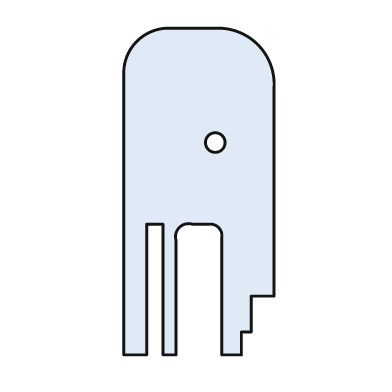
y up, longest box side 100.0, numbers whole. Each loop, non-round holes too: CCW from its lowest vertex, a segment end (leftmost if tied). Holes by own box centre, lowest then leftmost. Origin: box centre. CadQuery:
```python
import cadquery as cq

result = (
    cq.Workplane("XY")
    .moveTo(-23.0, -50.0)
    .lineTo(-16.0, -50.0)
    .lineTo(-16.0, -10.0)
    .lineTo(-11.0, -10.0)
    .lineTo(-11.0, -50.0)
    .lineTo(-7.0, -50.0)
    .lineTo(-7.0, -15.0)
    .threePointArc((-6.0, -11.0), (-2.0, -10.0))
    .lineTo(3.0, -10.0)
    .threePointArc((6.0, -11.0), (7.0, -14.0))
    .lineTo(7.0, -50.0)
    .lineTo(13.0, -50.0)
    .lineTo(13.0, -43.0)
    .lineTo(16.0, -43.0)
    .lineTo(16.0, -32.0)
    .lineTo(23.0, -32.0)
    .lineTo(23.0, 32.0)
    .threePointArc((18.0, 45.0), (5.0, 50.0))
    .lineTo(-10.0, 50.0)
    .threePointArc((-19.0, 46.0), (-23.0, 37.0))
    .close()
    .moveTo(5.0, 15.0)
    .circle(3.0)
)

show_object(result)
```